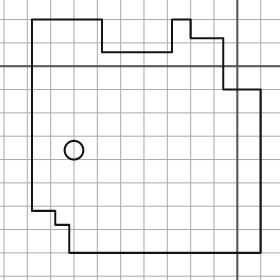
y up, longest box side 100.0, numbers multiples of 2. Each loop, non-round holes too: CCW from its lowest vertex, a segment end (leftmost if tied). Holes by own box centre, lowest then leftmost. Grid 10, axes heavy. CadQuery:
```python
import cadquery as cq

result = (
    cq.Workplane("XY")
    .moveTo(-72.0, -80.0)
    .lineTo(10.0, -80.0)
    .lineTo(10.0, -10.0)
    .lineTo(-6.0, -10.0)
    .lineTo(-6.0, 12.0)
    .lineTo(-20.0, 12.0)
    .lineTo(-20.0, 20.0)
    .lineTo(-28.0, 20.0)
    .lineTo(-28.0, 6.0)
    .lineTo(-58.0, 6.0)
    .lineTo(-58.0, 20.0)
    .lineTo(-88.0, 20.0)
    .lineTo(-88.0, -62.0)
    .lineTo(-78.0, -62.0)
    .lineTo(-78.0, -68.0)
    .lineTo(-72.0, -68.0)
    .close()
    .moveTo(-70.0, -36.0)
    .circle(4.0)
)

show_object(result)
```